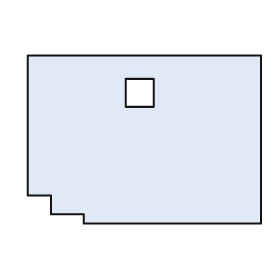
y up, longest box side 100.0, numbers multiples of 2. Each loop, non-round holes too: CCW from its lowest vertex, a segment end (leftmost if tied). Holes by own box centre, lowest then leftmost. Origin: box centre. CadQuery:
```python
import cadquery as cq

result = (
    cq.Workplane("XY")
    .moveTo(-26.0, -36.0)
    .lineTo(50.0, -36.0)
    .lineTo(50.0, 36.0)
    .lineTo(-50.0, 36.0)
    .lineTo(-50.0, -24.0)
    .lineTo(-40.0, -24.0)
    .lineTo(-40.0, -32.0)
    .lineTo(-26.0, -32.0)
    .close()
    .moveTo(-8.0, 14.0)
    .lineTo(4.0, 14.0)
    .lineTo(4.0, 26.0)
    .lineTo(-8.0, 26.0)
    .close()
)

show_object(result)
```